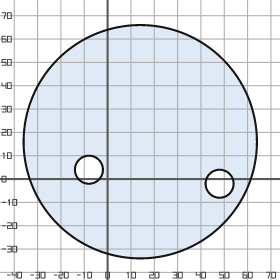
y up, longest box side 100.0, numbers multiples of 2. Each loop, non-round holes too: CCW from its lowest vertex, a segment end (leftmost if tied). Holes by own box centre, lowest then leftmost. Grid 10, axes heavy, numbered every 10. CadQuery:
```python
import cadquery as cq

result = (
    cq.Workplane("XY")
    .moveTo(14.0, 16.0)
    .circle(50.0)
    .moveTo(48.0, -2.0)
    .circle(6.0)
    .moveTo(-8.0, 4.0)
    .circle(6.0)
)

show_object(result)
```